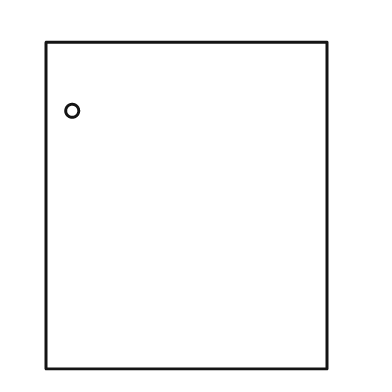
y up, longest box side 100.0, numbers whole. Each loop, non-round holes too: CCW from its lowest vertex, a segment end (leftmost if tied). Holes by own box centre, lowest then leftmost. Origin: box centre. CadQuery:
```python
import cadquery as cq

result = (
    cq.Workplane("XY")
    .moveTo(-43.0, -50.0)
    .lineTo(43.0, -50.0)
    .lineTo(43.0, 50.0)
    .lineTo(-43.0, 50.0)
    .close()
    .moveTo(-35.0, 29.0)
    .circle(2.0)
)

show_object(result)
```